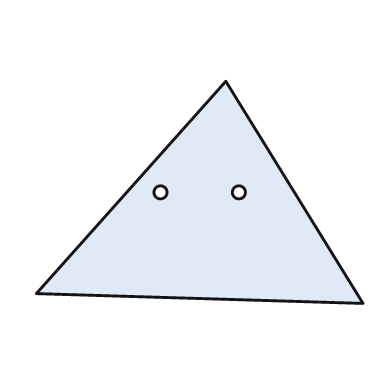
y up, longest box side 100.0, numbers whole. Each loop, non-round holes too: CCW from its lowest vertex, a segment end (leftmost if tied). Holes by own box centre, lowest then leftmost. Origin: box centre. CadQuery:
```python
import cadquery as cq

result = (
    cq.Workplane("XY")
    .moveTo(50.0, -34.0)
    .lineTo(8.0, 34.0)
    .lineTo(-50.0, -31.0)
    .close()
    .moveTo(-12.0, 0.0)
    .circle(2.0)
    .moveTo(12.0, 0.0)
    .circle(2.0)
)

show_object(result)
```